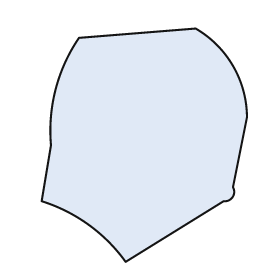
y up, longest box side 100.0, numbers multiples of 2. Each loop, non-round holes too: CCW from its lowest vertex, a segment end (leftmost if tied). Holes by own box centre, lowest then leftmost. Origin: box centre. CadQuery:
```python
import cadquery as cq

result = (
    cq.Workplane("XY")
    .moveTo(-8.0, -50.0)
    .lineTo(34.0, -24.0)
    .threePointArc((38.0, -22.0), (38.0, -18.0))
    .lineTo(44.0, 12.0)
    .threePointArc((38.0, 34.0), (22.0, 50.0))
    .lineTo(-28.0, 46.0)
    .threePointArc((-38.0, 24.0), (-40.0, 0.0))
    .lineTo(-44.0, -24.0)
    .threePointArc((-24.0, -34.0), (-8.0, -50.0))
    .close()
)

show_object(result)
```